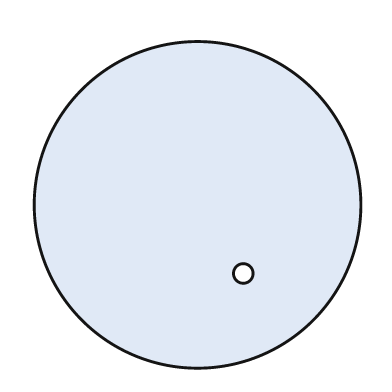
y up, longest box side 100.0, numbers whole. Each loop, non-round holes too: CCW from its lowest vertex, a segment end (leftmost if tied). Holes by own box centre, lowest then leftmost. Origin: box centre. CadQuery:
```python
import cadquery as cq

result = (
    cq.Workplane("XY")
    .moveTo(0.0, 0.0)
    .circle(50.0)
    .moveTo(14.0, -21.0)
    .circle(3.0)
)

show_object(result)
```